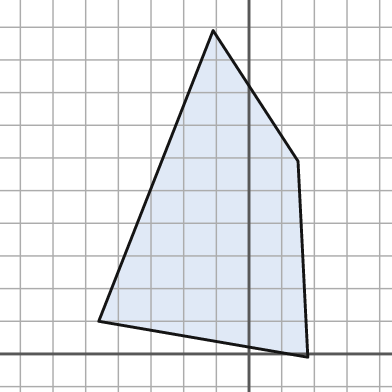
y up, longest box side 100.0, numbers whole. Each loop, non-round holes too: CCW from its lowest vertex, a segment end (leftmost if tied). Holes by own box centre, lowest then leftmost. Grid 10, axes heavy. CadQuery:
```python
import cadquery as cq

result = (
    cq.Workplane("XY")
    .moveTo(18.0, -1.0)
    .lineTo(15.0, 59.0)
    .lineTo(-11.0, 99.0)
    .lineTo(-46.0, 10.0)
    .close()
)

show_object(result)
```